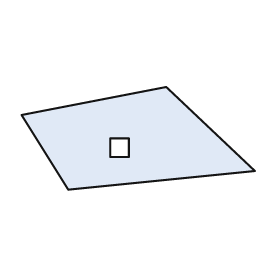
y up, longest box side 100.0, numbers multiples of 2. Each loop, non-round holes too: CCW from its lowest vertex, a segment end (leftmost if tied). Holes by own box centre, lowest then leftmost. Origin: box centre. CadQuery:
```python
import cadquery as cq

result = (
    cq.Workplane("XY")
    .moveTo(-30.0, -22.0)
    .lineTo(50.0, -14.0)
    .lineTo(12.0, 22.0)
    .lineTo(-50.0, 10.0)
    .close()
    .moveTo(-12.0, -8.0)
    .lineTo(-4.0, -8.0)
    .lineTo(-4.0, 0.0)
    .lineTo(-12.0, 0.0)
    .close()
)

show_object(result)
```